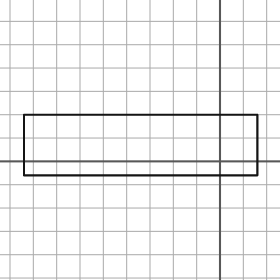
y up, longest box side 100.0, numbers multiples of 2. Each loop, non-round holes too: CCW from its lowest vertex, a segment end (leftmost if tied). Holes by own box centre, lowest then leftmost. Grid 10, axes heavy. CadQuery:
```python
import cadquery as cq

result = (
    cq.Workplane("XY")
    .moveTo(-84.0, -6.0)
    .lineTo(16.0, -6.0)
    .lineTo(16.0, 20.0)
    .lineTo(-84.0, 20.0)
    .close()
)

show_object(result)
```